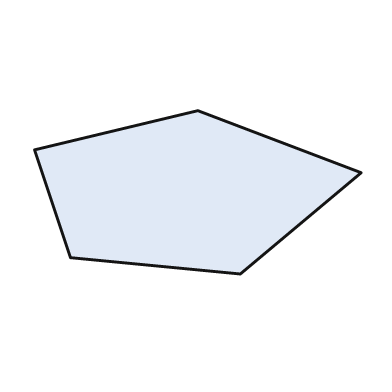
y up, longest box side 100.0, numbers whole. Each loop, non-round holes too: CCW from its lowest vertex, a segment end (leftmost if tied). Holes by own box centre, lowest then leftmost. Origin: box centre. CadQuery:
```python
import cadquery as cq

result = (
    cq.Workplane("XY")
    .moveTo(13.0, -25.0)
    .lineTo(50.0, 6.0)
    .lineTo(0.0, 25.0)
    .lineTo(-50.0, 13.0)
    .lineTo(-39.0, -20.0)
    .close()
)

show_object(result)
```